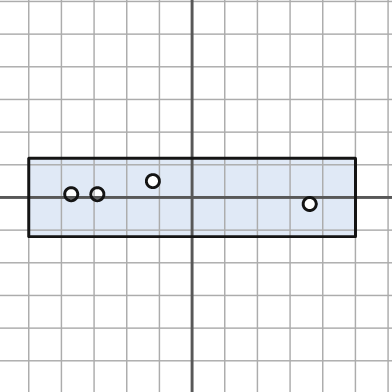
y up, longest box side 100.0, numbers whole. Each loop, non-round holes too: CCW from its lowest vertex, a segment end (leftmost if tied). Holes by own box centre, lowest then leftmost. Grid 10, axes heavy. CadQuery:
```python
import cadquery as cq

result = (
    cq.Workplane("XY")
    .moveTo(-50.0, -12.0)
    .lineTo(50.0, -12.0)
    .lineTo(50.0, 12.0)
    .lineTo(-50.0, 12.0)
    .close()
    .moveTo(36.0, -2.0)
    .circle(2.0)
    .moveTo(-37.0, 1.0)
    .circle(2.0)
    .moveTo(-29.0, 1.0)
    .circle(2.0)
    .moveTo(-12.0, 5.0)
    .circle(2.0)
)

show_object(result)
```